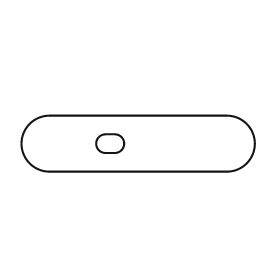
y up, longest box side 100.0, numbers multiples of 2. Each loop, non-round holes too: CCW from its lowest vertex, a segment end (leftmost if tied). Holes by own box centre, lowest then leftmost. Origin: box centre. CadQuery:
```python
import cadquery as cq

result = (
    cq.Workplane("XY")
    .moveTo(-38.0, -12.0)
    .lineTo(38.0, -12.0)
    .threePointArc((50.0, 0.0), (38.0, 12.0))
    .lineTo(-38.0, 12.0)
    .threePointArc((-50.0, 0.0), (-38.0, -12.0))
    .close()
    .moveTo(-14.0, -4.0)
    .lineTo(-10.0, -4.0)
    .threePointArc((-6.0, 0.0), (-10.0, 4.0))
    .lineTo(-14.0, 4.0)
    .threePointArc((-18.0, 0.0), (-14.0, -4.0))
    .close()
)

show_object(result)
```